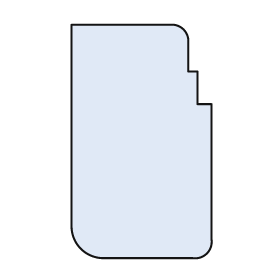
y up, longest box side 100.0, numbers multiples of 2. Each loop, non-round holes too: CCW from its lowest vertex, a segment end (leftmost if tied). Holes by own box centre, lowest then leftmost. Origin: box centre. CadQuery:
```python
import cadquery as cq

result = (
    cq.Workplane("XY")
    .moveTo(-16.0, -50.0)
    .lineTo(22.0, -50.0)
    .threePointArc((28.0, -48.0), (30.0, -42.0))
    .lineTo(30.0, 16.0)
    .lineTo(24.0, 16.0)
    .lineTo(24.0, 30.0)
    .lineTo(20.0, 30.0)
    .lineTo(20.0, 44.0)
    .threePointArc((18.0, 48.0), (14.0, 50.0))
    .lineTo(-30.0, 50.0)
    .lineTo(-30.0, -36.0)
    .threePointArc((-26.0, -46.0), (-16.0, -50.0))
    .close()
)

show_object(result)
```